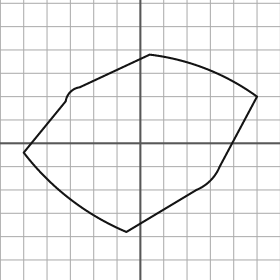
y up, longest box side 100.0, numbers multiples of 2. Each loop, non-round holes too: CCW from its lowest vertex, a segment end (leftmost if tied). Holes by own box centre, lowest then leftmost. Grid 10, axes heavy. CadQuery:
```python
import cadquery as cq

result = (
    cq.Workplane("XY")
    .moveTo(-6.0, -38.0)
    .lineTo(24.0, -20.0)
    .threePointArc((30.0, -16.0), (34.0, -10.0))
    .lineTo(50.0, 20.0)
    .threePointArc((28.0, 32.0), (4.0, 38.0))
    .lineTo(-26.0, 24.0)
    .threePointArc((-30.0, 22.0), (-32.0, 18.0))
    .lineTo(-50.0, -4.0)
    .threePointArc((-30.0, -24.0), (-6.0, -38.0))
    .close()
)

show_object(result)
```